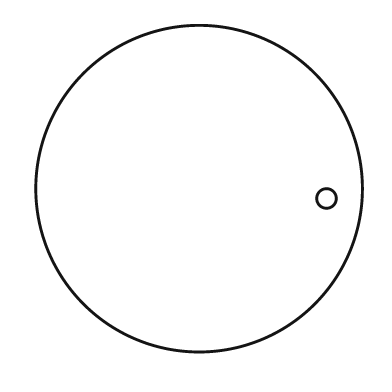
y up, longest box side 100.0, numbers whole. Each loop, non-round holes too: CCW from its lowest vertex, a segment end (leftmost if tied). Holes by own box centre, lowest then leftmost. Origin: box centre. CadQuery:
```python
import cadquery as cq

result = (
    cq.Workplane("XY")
    .moveTo(0.0, 0.0)
    .circle(50.0)
    .moveTo(39.0, -3.0)
    .circle(3.0)
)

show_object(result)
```